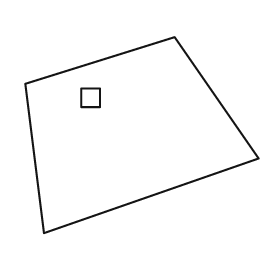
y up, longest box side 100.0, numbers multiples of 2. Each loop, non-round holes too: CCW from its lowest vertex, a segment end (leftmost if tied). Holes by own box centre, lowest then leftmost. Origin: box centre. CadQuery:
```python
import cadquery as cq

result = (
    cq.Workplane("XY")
    .moveTo(-42.0, -42.0)
    .lineTo(50.0, -10.0)
    .lineTo(14.0, 42.0)
    .lineTo(-50.0, 22.0)
    .close()
    .moveTo(-26.0, 12.0)
    .lineTo(-18.0, 12.0)
    .lineTo(-18.0, 20.0)
    .lineTo(-26.0, 20.0)
    .close()
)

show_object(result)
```